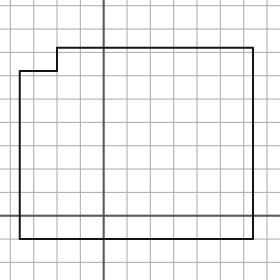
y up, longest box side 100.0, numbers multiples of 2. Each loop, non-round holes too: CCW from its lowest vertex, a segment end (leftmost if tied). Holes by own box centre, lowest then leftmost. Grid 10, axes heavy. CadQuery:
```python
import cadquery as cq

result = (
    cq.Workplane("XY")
    .moveTo(-36.0, -10.0)
    .lineTo(64.0, -10.0)
    .lineTo(64.0, 72.0)
    .lineTo(-20.0, 72.0)
    .lineTo(-20.0, 62.0)
    .lineTo(-36.0, 62.0)
    .close()
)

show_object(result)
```